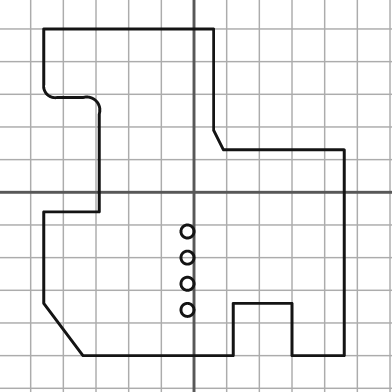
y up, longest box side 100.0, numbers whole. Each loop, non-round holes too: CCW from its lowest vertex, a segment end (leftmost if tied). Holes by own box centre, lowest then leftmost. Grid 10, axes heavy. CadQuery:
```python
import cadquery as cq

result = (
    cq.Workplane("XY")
    .moveTo(-34.0, -50.0)
    .lineTo(12.0, -50.0)
    .lineTo(12.0, -34.0)
    .lineTo(30.0, -34.0)
    .lineTo(30.0, -50.0)
    .lineTo(46.0, -50.0)
    .lineTo(46.0, 13.0)
    .lineTo(9.0, 13.0)
    .lineTo(6.0, 19.0)
    .lineTo(6.0, 50.0)
    .lineTo(-46.0, 50.0)
    .lineTo(-46.0, 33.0)
    .threePointArc((-45.0, 30.0), (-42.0, 29.0))
    .lineTo(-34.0, 29.0)
    .threePointArc((-30.0, 28.0), (-29.0, 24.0))
    .lineTo(-29.0, -6.0)
    .lineTo(-46.0, -6.0)
    .lineTo(-46.0, -34.0)
    .close()
    .moveTo(-2.0, -36.0)
    .circle(2.0)
    .moveTo(-2.0, -28.0)
    .circle(2.0)
    .moveTo(-2.0, -20.0)
    .circle(2.0)
    .moveTo(-2.0, -12.0)
    .circle(2.0)
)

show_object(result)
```